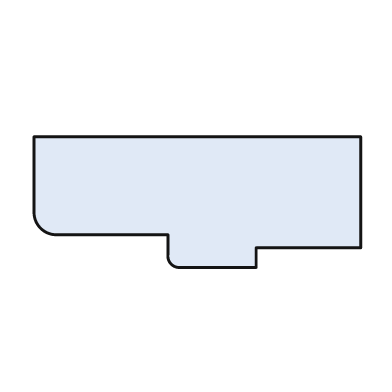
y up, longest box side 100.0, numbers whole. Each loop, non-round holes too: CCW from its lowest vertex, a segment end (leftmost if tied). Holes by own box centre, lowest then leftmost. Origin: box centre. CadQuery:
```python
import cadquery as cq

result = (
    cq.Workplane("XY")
    .moveTo(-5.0, -20.0)
    .lineTo(18.0, -20.0)
    .lineTo(18.0, -14.0)
    .lineTo(50.0, -14.0)
    .lineTo(50.0, 20.0)
    .lineTo(-50.0, 20.0)
    .lineTo(-50.0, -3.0)
    .threePointArc((-48.0, -8.0), (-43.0, -10.0))
    .lineTo(-9.0, -10.0)
    .lineTo(-9.0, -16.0)
    .threePointArc((-8.0, -19.0), (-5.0, -20.0))
    .close()
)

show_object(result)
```